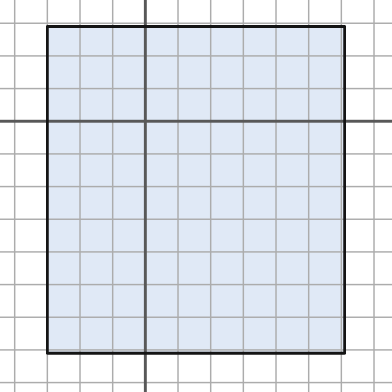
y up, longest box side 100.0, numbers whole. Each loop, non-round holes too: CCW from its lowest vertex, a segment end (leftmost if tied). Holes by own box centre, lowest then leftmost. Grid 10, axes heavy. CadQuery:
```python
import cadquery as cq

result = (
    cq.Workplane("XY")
    .moveTo(-30.0, -71.0)
    .lineTo(61.0, -71.0)
    .lineTo(61.0, 29.0)
    .lineTo(-30.0, 29.0)
    .close()
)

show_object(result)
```